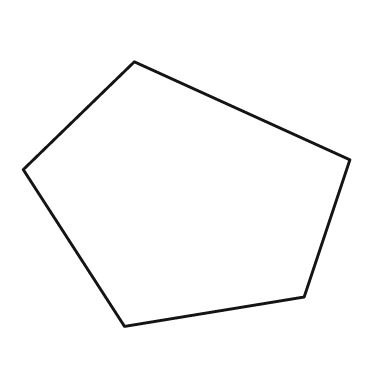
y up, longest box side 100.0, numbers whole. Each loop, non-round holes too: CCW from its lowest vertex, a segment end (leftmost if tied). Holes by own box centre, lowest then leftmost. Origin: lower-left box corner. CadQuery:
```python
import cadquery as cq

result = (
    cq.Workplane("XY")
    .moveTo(31.0, 0.0)
    .lineTo(86.0, 9.0)
    .lineTo(100.0, 51.0)
    .lineTo(34.0, 81.0)
    .lineTo(0.0, 48.0)
    .close()
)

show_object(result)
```